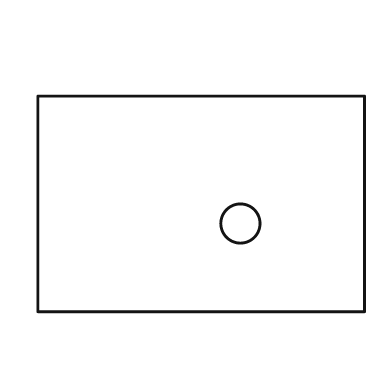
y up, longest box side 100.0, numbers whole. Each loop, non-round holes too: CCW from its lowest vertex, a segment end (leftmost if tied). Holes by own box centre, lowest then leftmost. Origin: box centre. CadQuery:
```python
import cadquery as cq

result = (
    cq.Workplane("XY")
    .moveTo(-50.0, -33.0)
    .lineTo(50.0, -33.0)
    .lineTo(50.0, 33.0)
    .lineTo(-50.0, 33.0)
    .close()
    .moveTo(12.0, -6.0)
    .circle(6.0)
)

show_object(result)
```